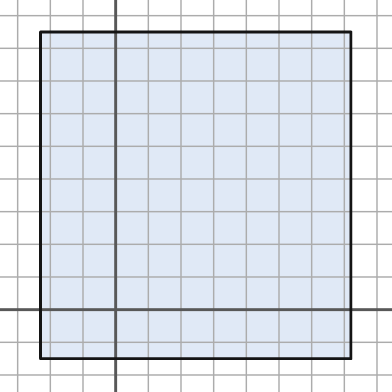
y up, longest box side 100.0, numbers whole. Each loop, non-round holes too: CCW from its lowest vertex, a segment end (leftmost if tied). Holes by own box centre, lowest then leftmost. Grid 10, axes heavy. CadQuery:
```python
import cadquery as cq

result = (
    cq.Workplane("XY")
    .moveTo(-23.0, -15.0)
    .lineTo(72.0, -15.0)
    .lineTo(72.0, 85.0)
    .lineTo(-23.0, 85.0)
    .close()
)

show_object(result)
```